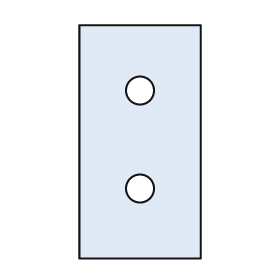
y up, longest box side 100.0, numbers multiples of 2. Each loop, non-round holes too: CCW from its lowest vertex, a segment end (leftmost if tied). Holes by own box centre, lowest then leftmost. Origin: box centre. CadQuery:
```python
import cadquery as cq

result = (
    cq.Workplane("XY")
    .moveTo(-26.0, -50.0)
    .lineTo(26.0, -50.0)
    .lineTo(26.0, 50.0)
    .lineTo(-26.0, 50.0)
    .close()
    .moveTo(0.0, -20.0)
    .circle(6.0)
    .moveTo(0.0, 22.0)
    .circle(6.0)
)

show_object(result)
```